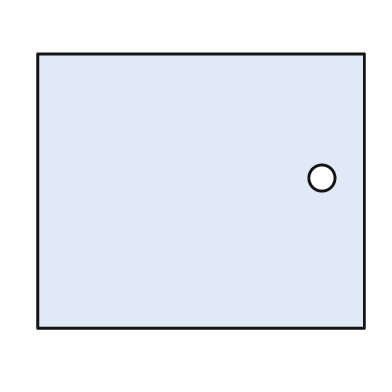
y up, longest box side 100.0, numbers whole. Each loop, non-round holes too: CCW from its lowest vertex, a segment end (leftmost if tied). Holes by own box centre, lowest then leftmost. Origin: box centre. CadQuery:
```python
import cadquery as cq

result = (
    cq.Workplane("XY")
    .moveTo(-50.0, -42.0)
    .lineTo(50.0, -42.0)
    .lineTo(50.0, 42.0)
    .lineTo(-50.0, 42.0)
    .close()
    .moveTo(37.0, 4.0)
    .circle(4.0)
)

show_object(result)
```